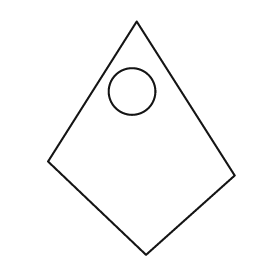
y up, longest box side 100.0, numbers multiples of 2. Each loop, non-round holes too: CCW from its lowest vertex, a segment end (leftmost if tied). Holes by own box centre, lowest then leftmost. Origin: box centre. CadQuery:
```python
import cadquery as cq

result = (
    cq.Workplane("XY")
    .moveTo(2.0, -50.0)
    .lineTo(40.0, -16.0)
    .lineTo(-2.0, 50.0)
    .lineTo(-40.0, -10.0)
    .close()
    .moveTo(-4.0, 20.0)
    .circle(10.0)
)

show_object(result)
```